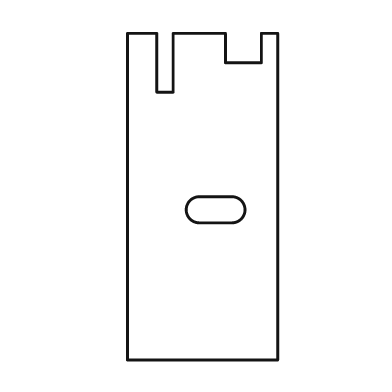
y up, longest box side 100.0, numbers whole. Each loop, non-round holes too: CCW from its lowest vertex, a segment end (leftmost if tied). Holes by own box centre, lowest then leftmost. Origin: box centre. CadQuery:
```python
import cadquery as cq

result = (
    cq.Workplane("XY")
    .moveTo(-23.0, -50.0)
    .lineTo(23.0, -50.0)
    .lineTo(23.0, 50.0)
    .lineTo(18.0, 50.0)
    .lineTo(18.0, 41.0)
    .lineTo(7.0, 41.0)
    .lineTo(7.0, 50.0)
    .lineTo(-9.0, 50.0)
    .lineTo(-9.0, 32.0)
    .lineTo(-14.0, 32.0)
    .lineTo(-14.0, 50.0)
    .lineTo(-23.0, 50.0)
    .close()
    .moveTo(-1.0, -8.0)
    .lineTo(9.0, -8.0)
    .threePointArc((13.0, -4.0), (9.0, 0.0))
    .lineTo(-1.0, 0.0)
    .threePointArc((-5.0, -4.0), (-1.0, -8.0))
    .close()
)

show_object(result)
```